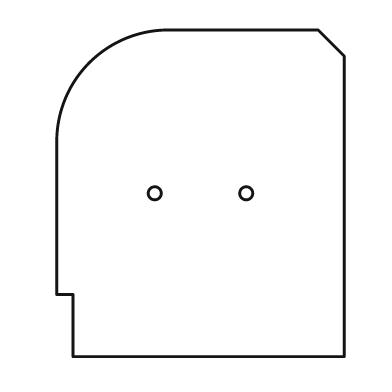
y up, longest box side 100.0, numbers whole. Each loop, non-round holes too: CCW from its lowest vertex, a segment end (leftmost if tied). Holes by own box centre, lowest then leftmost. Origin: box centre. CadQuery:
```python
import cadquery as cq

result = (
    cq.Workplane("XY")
    .moveTo(-39.0, -50.0)
    .lineTo(44.0, -50.0)
    .lineTo(44.0, 42.0)
    .lineTo(36.0, 50.0)
    .lineTo(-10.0, 50.0)
    .threePointArc((-34.0, 40.0), (-44.0, 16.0))
    .lineTo(-44.0, -31.0)
    .lineTo(-39.0, -31.0)
    .close()
    .moveTo(-14.0, 0.0)
    .circle(2.0)
    .moveTo(14.0, 0.0)
    .circle(2.0)
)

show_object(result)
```